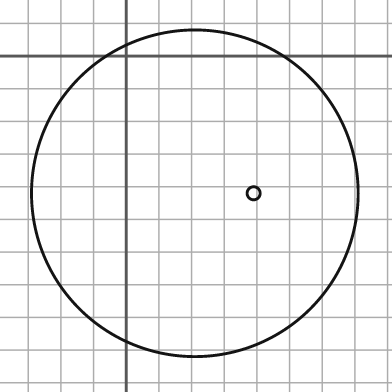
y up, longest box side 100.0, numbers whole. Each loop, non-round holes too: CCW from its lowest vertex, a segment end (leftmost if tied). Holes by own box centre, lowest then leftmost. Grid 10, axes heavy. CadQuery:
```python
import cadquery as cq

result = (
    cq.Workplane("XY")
    .moveTo(21.0, -42.0)
    .circle(50.0)
    .moveTo(39.0, -42.0)
    .circle(2.0)
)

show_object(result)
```